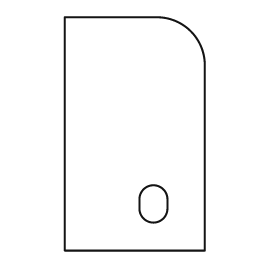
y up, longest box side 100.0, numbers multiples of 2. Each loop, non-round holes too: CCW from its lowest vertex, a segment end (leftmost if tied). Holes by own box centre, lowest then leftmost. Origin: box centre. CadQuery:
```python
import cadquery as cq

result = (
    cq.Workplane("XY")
    .moveTo(-30.0, -50.0)
    .lineTo(30.0, -50.0)
    .lineTo(30.0, 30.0)
    .threePointArc((24.0, 44.0), (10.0, 50.0))
    .lineTo(-30.0, 50.0)
    .close()
    .moveTo(2.0, -32.0)
    .threePointArc((8.0, -38.0), (14.0, -32.0))
    .lineTo(14.0, -28.0)
    .threePointArc((8.0, -22.0), (2.0, -28.0))
    .close()
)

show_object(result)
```